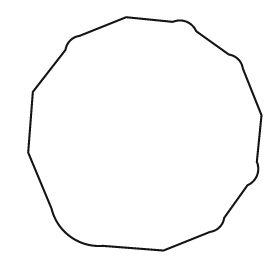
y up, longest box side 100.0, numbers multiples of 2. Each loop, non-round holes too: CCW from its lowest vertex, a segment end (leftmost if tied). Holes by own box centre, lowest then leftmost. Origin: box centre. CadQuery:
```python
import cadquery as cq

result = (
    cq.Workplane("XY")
    .moveTo(8.0, -50.0)
    .lineTo(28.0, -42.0)
    .threePointArc((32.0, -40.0), (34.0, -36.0))
    .lineTo(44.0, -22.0)
    .threePointArc((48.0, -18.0), (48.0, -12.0))
    .lineTo(50.0, 8.0)
    .lineTo(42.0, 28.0)
    .threePointArc((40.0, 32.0), (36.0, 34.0))
    .lineTo(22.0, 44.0)
    .threePointArc((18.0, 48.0), (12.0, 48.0))
    .lineTo(-8.0, 50.0)
    .lineTo(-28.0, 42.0)
    .threePointArc((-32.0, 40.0), (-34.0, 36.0))
    .lineTo(-48.0, 18.0)
    .lineTo(-50.0, -8.0)
    .lineTo(-40.0, -32.0)
    .threePointArc((-32.0, -44.0), (-18.0, -48.0))
    .close()
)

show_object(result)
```